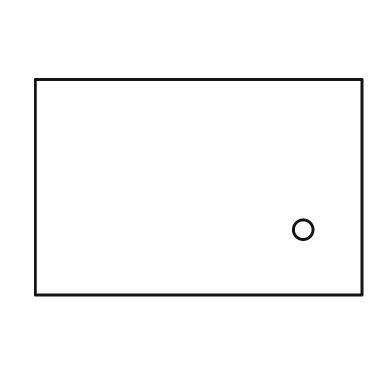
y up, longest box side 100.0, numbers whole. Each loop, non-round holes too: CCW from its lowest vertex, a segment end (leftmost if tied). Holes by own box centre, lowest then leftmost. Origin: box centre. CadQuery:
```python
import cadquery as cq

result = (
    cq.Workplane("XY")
    .moveTo(-50.0, -33.0)
    .lineTo(50.0, -33.0)
    .lineTo(50.0, 33.0)
    .lineTo(-50.0, 33.0)
    .close()
    .moveTo(32.0, -13.0)
    .circle(3.0)
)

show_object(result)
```